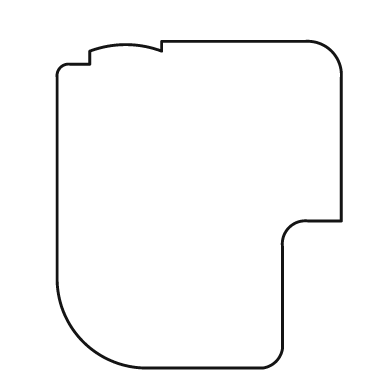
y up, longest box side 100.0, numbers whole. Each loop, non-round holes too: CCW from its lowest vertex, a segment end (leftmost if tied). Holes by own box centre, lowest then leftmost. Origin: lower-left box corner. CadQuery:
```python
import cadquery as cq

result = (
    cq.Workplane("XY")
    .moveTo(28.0, 0.0)
    .lineTo(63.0, 0.0)
    .threePointArc((67.0, 2.0), (69.0, 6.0))
    .lineTo(69.0, 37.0)
    .threePointArc((71.0, 43.0), (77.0, 45.0))
    .lineTo(87.0, 45.0)
    .lineTo(87.0, 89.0)
    .threePointArc((84.0, 97.0), (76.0, 100.0))
    .lineTo(32.0, 100.0)
    .lineTo(32.0, 97.0)
    .threePointArc((21.0, 99.0), (10.0, 97.0))
    .lineTo(10.0, 93.0)
    .lineTo(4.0, 93.0)
    .threePointArc((1.0, 92.0), (0.0, 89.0))
    .lineTo(0.0, 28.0)
    .threePointArc((8.0, 8.0), (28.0, 0.0))
    .close()
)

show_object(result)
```